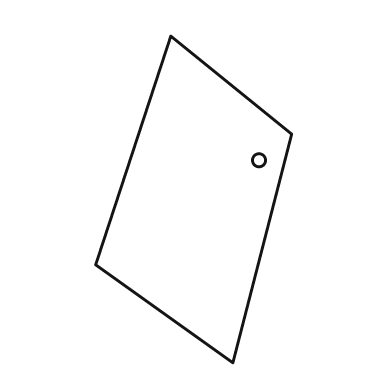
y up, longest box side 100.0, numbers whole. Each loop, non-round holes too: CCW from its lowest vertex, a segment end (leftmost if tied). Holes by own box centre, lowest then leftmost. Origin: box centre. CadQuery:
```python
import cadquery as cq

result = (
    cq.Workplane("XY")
    .moveTo(12.0, -50.0)
    .lineTo(30.0, 20.0)
    .lineTo(-7.0, 50.0)
    .lineTo(-30.0, -20.0)
    .close()
    .moveTo(20.0, 12.0)
    .circle(2.0)
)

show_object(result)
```